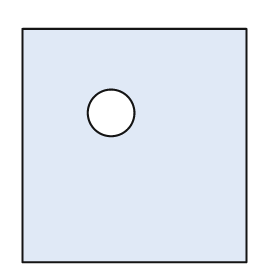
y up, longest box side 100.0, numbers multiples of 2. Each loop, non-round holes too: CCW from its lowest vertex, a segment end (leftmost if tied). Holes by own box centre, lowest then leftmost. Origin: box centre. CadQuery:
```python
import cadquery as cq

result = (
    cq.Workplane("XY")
    .moveTo(-48.0, -50.0)
    .lineTo(48.0, -50.0)
    .lineTo(48.0, 50.0)
    .lineTo(-48.0, 50.0)
    .close()
    .moveTo(-10.0, 14.0)
    .circle(10.0)
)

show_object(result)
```